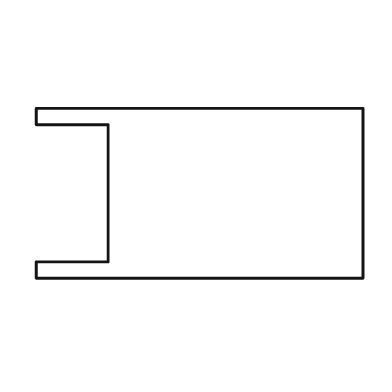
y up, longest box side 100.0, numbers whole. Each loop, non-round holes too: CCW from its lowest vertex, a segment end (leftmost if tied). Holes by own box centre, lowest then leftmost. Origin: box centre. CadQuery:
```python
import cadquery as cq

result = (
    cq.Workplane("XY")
    .moveTo(-50.0, -26.0)
    .lineTo(50.0, -26.0)
    .lineTo(50.0, 26.0)
    .lineTo(-50.0, 26.0)
    .lineTo(-50.0, 21.0)
    .lineTo(-28.0, 21.0)
    .lineTo(-28.0, -21.0)
    .lineTo(-50.0, -21.0)
    .close()
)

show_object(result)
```